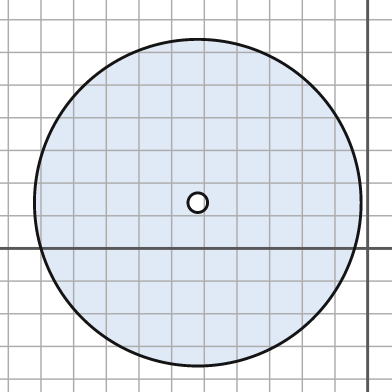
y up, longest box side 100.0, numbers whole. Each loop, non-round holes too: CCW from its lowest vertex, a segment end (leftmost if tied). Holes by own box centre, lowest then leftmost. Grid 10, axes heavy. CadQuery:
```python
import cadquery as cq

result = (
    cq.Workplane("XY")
    .moveTo(-52.0, 14.0)
    .circle(50.0)
    .moveTo(-52.0, 14.0)
    .circle(3.0)
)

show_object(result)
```